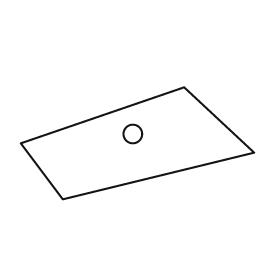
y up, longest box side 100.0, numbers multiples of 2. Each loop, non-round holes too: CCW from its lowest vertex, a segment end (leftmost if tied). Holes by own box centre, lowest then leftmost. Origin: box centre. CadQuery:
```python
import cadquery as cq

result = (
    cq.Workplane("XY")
    .moveTo(-32.0, -24.0)
    .lineTo(50.0, -4.0)
    .lineTo(20.0, 24.0)
    .lineTo(-50.0, 0.0)
    .close()
    .moveTo(-2.0, 4.0)
    .circle(4.0)
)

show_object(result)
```